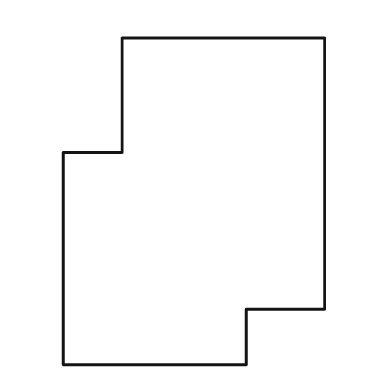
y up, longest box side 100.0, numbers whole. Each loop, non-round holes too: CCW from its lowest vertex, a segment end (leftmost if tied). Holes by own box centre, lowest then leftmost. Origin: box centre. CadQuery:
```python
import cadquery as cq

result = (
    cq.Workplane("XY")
    .moveTo(-40.0, -50.0)
    .lineTo(16.0, -50.0)
    .lineTo(16.0, -33.0)
    .lineTo(40.0, -33.0)
    .lineTo(40.0, 50.0)
    .lineTo(-22.0, 50.0)
    .lineTo(-22.0, 15.0)
    .lineTo(-40.0, 15.0)
    .close()
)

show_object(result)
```